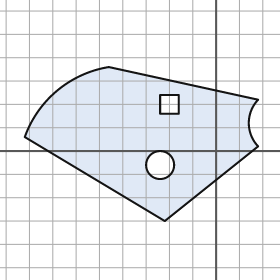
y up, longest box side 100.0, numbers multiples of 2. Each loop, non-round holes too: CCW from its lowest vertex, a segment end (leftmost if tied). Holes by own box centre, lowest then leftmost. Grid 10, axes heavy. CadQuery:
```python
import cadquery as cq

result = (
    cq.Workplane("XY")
    .moveTo(-22.0, -30.0)
    .lineTo(18.0, 2.0)
    .threePointArc((14.0, 12.0), (18.0, 22.0))
    .lineTo(-46.0, 36.0)
    .threePointArc((-68.0, 26.0), (-82.0, 6.0))
    .close()
    .moveTo(-24.0, -6.0)
    .circle(6.0)
    .moveTo(-24.0, 16.0)
    .lineTo(-16.0, 16.0)
    .lineTo(-16.0, 24.0)
    .lineTo(-24.0, 24.0)
    .close()
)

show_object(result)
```